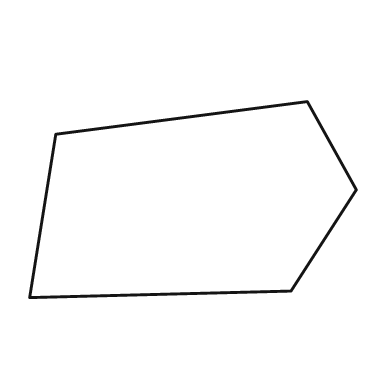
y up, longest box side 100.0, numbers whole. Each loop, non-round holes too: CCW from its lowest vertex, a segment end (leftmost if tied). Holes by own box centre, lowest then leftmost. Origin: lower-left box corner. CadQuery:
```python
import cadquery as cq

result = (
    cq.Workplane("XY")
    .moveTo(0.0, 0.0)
    .lineTo(80.0, 2.0)
    .lineTo(100.0, 33.0)
    .lineTo(85.0, 60.0)
    .lineTo(8.0, 50.0)
    .close()
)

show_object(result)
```